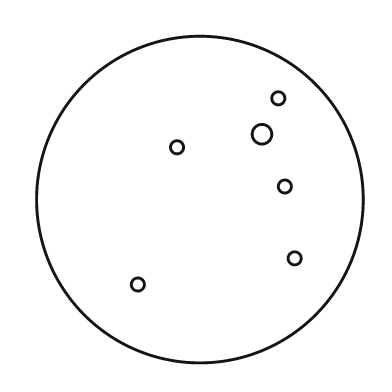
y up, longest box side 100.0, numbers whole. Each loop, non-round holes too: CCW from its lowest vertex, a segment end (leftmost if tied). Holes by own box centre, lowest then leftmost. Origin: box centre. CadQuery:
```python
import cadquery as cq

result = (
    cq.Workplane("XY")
    .moveTo(0.0, 0.0)
    .circle(50.0)
    .moveTo(-19.0, -26.0)
    .circle(2.0)
    .moveTo(29.0, -18.0)
    .circle(2.0)
    .moveTo(26.0, 4.0)
    .circle(2.0)
    .moveTo(-7.0, 16.0)
    .circle(2.0)
    .moveTo(19.0, 20.0)
    .circle(3.0)
    .moveTo(24.0, 31.0)
    .circle(2.0)
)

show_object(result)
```